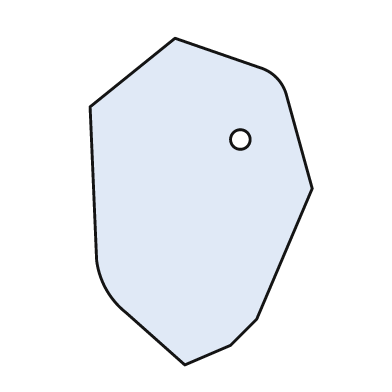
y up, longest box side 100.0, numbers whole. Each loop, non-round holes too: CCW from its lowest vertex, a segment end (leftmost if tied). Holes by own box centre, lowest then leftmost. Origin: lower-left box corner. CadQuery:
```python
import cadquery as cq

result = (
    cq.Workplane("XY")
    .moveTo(29.0, 0.0)
    .lineTo(43.0, 6.0)
    .lineTo(51.0, 14.0)
    .lineTo(68.0, 54.0)
    .lineTo(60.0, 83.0)
    .threePointArc((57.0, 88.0), (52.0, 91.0))
    .lineTo(26.0, 100.0)
    .lineTo(0.0, 79.0)
    .lineTo(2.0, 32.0)
    .threePointArc((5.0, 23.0), (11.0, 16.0))
    .close()
    .moveTo(46.0, 69.0)
    .circle(3.0)
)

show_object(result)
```